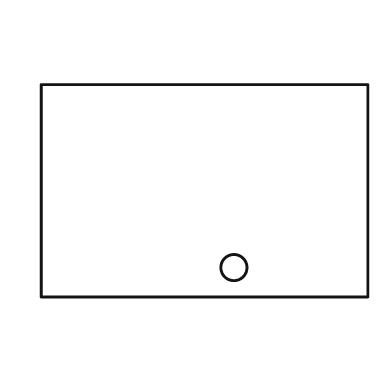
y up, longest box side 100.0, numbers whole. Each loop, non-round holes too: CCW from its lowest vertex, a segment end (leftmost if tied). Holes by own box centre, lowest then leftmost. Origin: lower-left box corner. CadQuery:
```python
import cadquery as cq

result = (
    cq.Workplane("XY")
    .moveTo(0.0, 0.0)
    .lineTo(100.0, 0.0)
    .lineTo(100.0, 65.0)
    .lineTo(0.0, 65.0)
    .close()
    .moveTo(59.0, 9.0)
    .circle(4.0)
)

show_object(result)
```